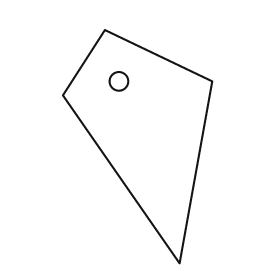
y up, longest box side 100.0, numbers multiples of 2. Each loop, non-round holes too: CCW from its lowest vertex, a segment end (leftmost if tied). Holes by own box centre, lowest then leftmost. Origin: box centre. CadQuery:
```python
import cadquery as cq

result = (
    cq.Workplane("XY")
    .moveTo(18.0, -50.0)
    .lineTo(32.0, 28.0)
    .lineTo(-14.0, 50.0)
    .lineTo(-32.0, 22.0)
    .close()
    .moveTo(-8.0, 28.0)
    .circle(4.0)
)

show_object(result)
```